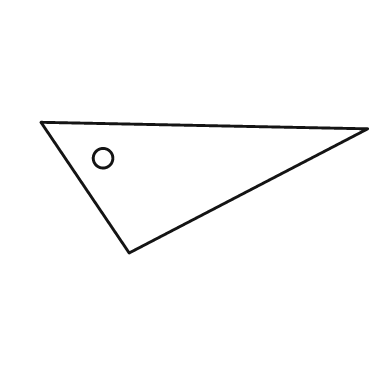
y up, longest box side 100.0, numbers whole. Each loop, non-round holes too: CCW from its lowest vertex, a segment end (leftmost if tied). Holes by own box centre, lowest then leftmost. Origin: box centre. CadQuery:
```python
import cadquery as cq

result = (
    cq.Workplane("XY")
    .moveTo(-23.0, -20.0)
    .lineTo(50.0, 18.0)
    .lineTo(-50.0, 20.0)
    .close()
    .moveTo(-31.0, 9.0)
    .circle(3.0)
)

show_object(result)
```